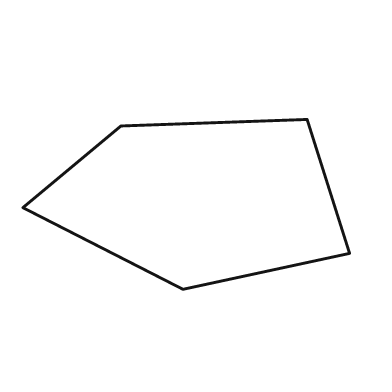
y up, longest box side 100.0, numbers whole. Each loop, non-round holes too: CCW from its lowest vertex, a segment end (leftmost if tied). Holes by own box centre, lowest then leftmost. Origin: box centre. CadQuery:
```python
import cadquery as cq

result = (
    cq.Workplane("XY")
    .moveTo(-1.0, -26.0)
    .lineTo(50.0, -15.0)
    .lineTo(37.0, 26.0)
    .lineTo(-20.0, 24.0)
    .lineTo(-50.0, -1.0)
    .close()
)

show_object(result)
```